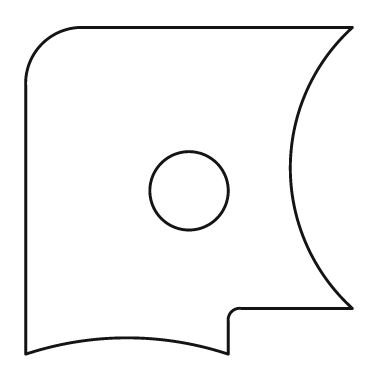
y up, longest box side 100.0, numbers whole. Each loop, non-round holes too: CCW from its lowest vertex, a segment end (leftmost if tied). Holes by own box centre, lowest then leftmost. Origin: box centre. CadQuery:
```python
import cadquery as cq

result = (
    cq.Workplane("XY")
    .moveTo(-50.0, -50.0)
    .threePointArc((-19.0, -45.0), (12.0, -50.0))
    .lineTo(12.0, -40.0)
    .threePointArc((13.0, -37.0), (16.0, -36.0))
    .lineTo(50.0, -36.0)
    .threePointArc((31.0, 7.0), (50.0, 50.0))
    .lineTo(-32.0, 50.0)
    .threePointArc((-45.0, 45.0), (-50.0, 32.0))
    .close()
    .moveTo(0.0, 0.0)
    .circle(12.0)
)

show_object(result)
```